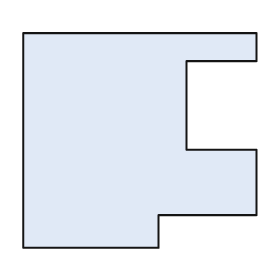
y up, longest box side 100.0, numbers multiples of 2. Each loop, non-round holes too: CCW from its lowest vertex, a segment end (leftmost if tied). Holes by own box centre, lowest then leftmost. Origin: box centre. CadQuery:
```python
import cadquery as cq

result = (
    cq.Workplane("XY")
    .moveTo(-50.0, -46.0)
    .lineTo(8.0, -46.0)
    .lineTo(8.0, -32.0)
    .lineTo(50.0, -32.0)
    .lineTo(50.0, -4.0)
    .lineTo(20.0, -4.0)
    .lineTo(20.0, 34.0)
    .lineTo(50.0, 34.0)
    .lineTo(50.0, 46.0)
    .lineTo(-50.0, 46.0)
    .close()
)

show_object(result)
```